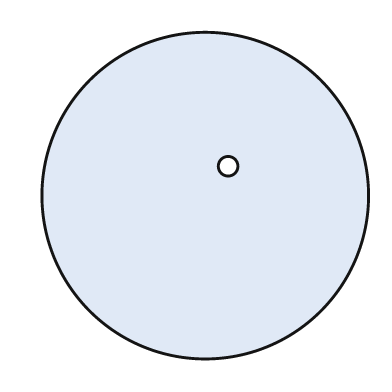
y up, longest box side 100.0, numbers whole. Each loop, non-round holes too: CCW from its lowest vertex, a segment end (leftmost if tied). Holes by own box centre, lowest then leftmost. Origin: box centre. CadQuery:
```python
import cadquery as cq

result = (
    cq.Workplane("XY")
    .moveTo(0.0, 0.0)
    .circle(50.0)
    .moveTo(7.0, 9.0)
    .circle(3.0)
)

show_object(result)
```